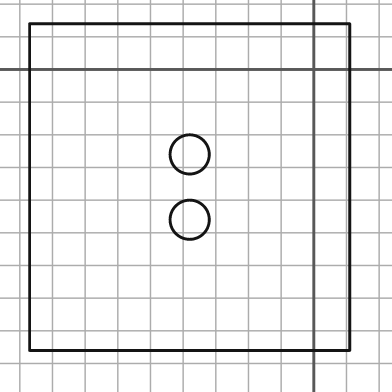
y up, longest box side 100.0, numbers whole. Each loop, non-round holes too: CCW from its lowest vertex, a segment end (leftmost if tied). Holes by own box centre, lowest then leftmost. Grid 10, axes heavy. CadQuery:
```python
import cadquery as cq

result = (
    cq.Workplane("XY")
    .moveTo(-87.0, -86.0)
    .lineTo(11.0, -86.0)
    .lineTo(11.0, 14.0)
    .lineTo(-87.0, 14.0)
    .close()
    .moveTo(-38.0, -46.0)
    .circle(6.0)
    .moveTo(-38.0, -26.0)
    .circle(6.0)
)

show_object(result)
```